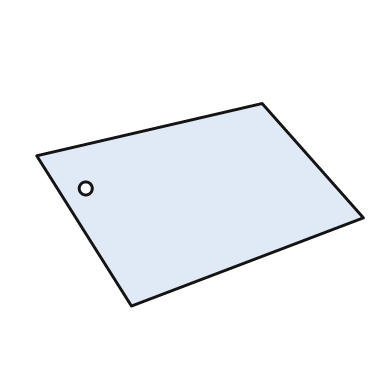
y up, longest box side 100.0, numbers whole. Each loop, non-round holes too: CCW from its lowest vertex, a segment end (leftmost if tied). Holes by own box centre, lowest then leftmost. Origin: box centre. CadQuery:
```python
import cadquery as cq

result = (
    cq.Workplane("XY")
    .moveTo(-21.0, -31.0)
    .lineTo(50.0, -4.0)
    .lineTo(19.0, 31.0)
    .lineTo(-50.0, 15.0)
    .close()
    .moveTo(-35.0, 5.0)
    .circle(2.0)
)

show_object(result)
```